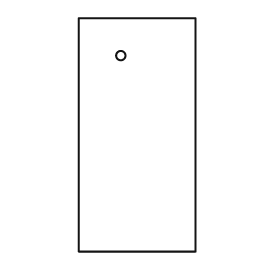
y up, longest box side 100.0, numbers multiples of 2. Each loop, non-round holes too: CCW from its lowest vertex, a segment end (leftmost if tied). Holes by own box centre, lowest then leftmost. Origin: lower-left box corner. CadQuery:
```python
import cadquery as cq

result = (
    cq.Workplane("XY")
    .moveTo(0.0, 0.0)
    .lineTo(50.0, 0.0)
    .lineTo(50.0, 100.0)
    .lineTo(0.0, 100.0)
    .close()
    .moveTo(18.0, 84.0)
    .circle(2.0)
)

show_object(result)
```